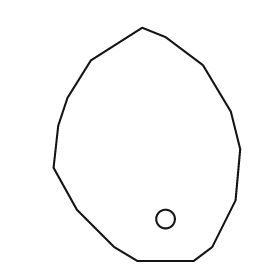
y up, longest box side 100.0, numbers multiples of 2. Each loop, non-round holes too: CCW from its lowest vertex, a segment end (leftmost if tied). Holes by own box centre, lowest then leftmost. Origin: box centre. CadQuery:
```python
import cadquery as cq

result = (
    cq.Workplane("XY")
    .moveTo(-4.0, -50.0)
    .lineTo(20.0, -50.0)
    .lineTo(28.0, -44.0)
    .lineTo(38.0, -24.0)
    .lineTo(40.0, -2.0)
    .lineTo(36.0, 14.0)
    .lineTo(24.0, 34.0)
    .lineTo(8.0, 46.0)
    .lineTo(-2.0, 50.0)
    .lineTo(-24.0, 36.0)
    .lineTo(-34.0, 20.0)
    .lineTo(-38.0, 8.0)
    .lineTo(-40.0, -10.0)
    .lineTo(-30.0, -28.0)
    .lineTo(-14.0, -44.0)
    .close()
    .moveTo(8.0, -32.0)
    .circle(4.0)
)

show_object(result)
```